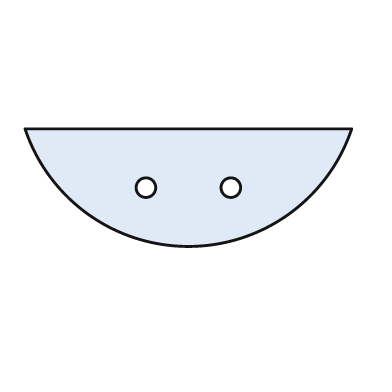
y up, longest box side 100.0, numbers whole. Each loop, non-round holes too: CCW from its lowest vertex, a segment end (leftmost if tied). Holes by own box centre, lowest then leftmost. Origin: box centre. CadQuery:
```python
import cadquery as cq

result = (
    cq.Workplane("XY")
    .moveTo(-50.0, 18.0)
    .threePointArc((0.0, -18.0), (50.0, 18.0))
    .close()
    .moveTo(-13.0, 0.0)
    .circle(3.0)
    .moveTo(13.0, 0.0)
    .circle(3.0)
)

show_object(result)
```